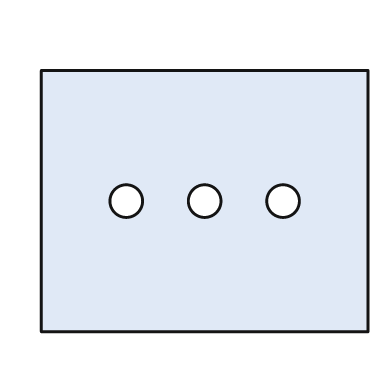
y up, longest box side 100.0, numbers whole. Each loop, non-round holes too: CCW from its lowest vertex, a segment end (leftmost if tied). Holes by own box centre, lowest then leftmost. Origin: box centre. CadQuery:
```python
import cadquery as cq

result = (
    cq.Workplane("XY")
    .moveTo(-50.0, -40.0)
    .lineTo(50.0, -40.0)
    .lineTo(50.0, 40.0)
    .lineTo(-50.0, 40.0)
    .close()
    .moveTo(-24.0, 0.0)
    .circle(5.0)
    .moveTo(0.0, 0.0)
    .circle(5.0)
    .moveTo(24.0, 0.0)
    .circle(5.0)
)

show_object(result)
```